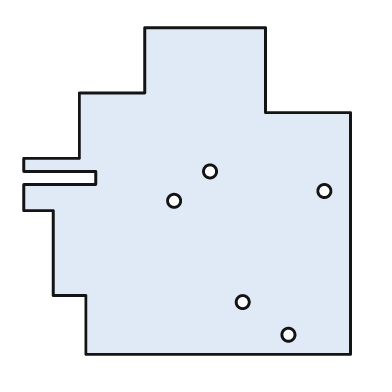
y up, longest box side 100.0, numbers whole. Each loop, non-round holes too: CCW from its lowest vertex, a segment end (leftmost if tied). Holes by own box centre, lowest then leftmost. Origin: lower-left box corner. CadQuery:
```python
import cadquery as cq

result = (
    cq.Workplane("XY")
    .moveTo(19.0, 0.0)
    .lineTo(100.0, 0.0)
    .lineTo(100.0, 74.0)
    .lineTo(74.0, 74.0)
    .lineTo(74.0, 100.0)
    .lineTo(37.0, 100.0)
    .lineTo(37.0, 80.0)
    .lineTo(17.0, 80.0)
    .lineTo(17.0, 60.0)
    .lineTo(0.0, 60.0)
    .lineTo(0.0, 56.0)
    .lineTo(22.0, 56.0)
    .lineTo(22.0, 52.0)
    .lineTo(0.0, 52.0)
    .lineTo(0.0, 44.0)
    .lineTo(9.0, 44.0)
    .lineTo(9.0, 18.0)
    .lineTo(19.0, 18.0)
    .close()
    .moveTo(81.0, 6.0)
    .circle(2.0)
    .moveTo(67.0, 16.0)
    .circle(2.0)
    .moveTo(46.0, 47.0)
    .circle(2.0)
    .moveTo(92.0, 50.0)
    .circle(2.0)
    .moveTo(57.0, 56.0)
    .circle(2.0)
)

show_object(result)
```